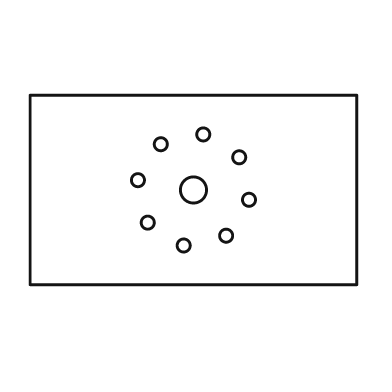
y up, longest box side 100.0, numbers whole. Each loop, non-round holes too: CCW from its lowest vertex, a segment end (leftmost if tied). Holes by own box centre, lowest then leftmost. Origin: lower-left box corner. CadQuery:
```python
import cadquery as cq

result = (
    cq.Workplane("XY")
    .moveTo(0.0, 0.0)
    .lineTo(100.0, 0.0)
    .lineTo(100.0, 58.0)
    .lineTo(0.0, 58.0)
    .close()
    .moveTo(47.0, 12.0)
    .circle(2.0)
    .moveTo(60.0, 15.0)
    .circle(2.0)
    .moveTo(36.0, 19.0)
    .circle(2.0)
    .moveTo(67.0, 26.0)
    .circle(2.0)
    .moveTo(50.0, 29.0)
    .circle(4.0)
    .moveTo(33.0, 32.0)
    .circle(2.0)
    .moveTo(64.0, 39.0)
    .circle(2.0)
    .moveTo(40.0, 43.0)
    .circle(2.0)
    .moveTo(53.0, 46.0)
    .circle(2.0)
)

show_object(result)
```